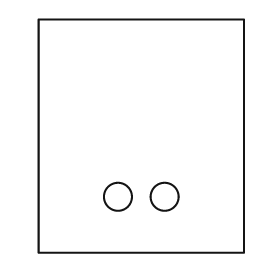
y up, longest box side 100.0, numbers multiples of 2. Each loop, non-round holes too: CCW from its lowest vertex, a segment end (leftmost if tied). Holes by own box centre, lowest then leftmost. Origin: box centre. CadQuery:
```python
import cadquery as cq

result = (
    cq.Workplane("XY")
    .moveTo(-44.0, -50.0)
    .lineTo(44.0, -50.0)
    .lineTo(44.0, 50.0)
    .lineTo(-44.0, 50.0)
    .close()
    .moveTo(-10.0, -26.0)
    .circle(6.0)
    .moveTo(10.0, -26.0)
    .circle(6.0)
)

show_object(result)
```